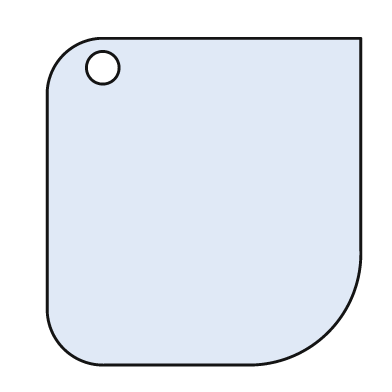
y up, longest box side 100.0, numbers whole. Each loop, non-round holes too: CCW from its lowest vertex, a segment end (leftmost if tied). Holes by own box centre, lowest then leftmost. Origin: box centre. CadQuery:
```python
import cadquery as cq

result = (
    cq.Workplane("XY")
    .moveTo(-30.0, -50.0)
    .lineTo(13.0, -50.0)
    .threePointArc((38.0, -40.0), (48.0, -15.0))
    .lineTo(48.0, 50.0)
    .lineTo(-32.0, 50.0)
    .threePointArc((-43.0, 45.0), (-48.0, 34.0))
    .lineTo(-48.0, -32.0)
    .threePointArc((-43.0, -45.0), (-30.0, -50.0))
    .close()
    .moveTo(-31.0, 41.0)
    .circle(5.0)
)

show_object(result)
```